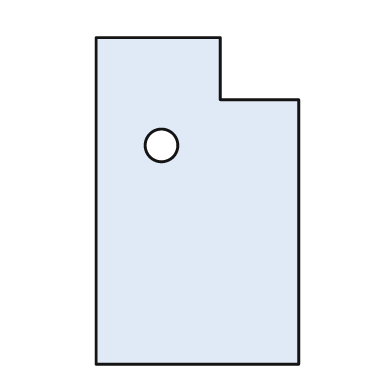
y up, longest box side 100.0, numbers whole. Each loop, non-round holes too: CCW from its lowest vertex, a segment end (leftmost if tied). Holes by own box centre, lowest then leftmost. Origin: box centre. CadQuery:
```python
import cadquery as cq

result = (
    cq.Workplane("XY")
    .moveTo(-31.0, -50.0)
    .lineTo(31.0, -50.0)
    .lineTo(31.0, 31.0)
    .lineTo(7.0, 31.0)
    .lineTo(7.0, 50.0)
    .lineTo(-31.0, 50.0)
    .close()
    .moveTo(-11.0, 17.0)
    .circle(5.0)
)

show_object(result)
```